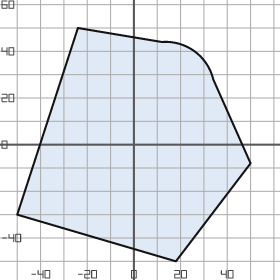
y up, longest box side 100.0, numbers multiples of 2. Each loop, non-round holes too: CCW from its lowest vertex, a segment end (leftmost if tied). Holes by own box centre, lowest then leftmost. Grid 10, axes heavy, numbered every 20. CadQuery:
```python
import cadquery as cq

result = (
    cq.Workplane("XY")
    .moveTo(18.0, -50.0)
    .lineTo(50.0, -8.0)
    .lineTo(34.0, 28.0)
    .threePointArc((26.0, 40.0), (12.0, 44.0))
    .lineTo(-24.0, 50.0)
    .lineTo(-50.0, -30.0)
    .close()
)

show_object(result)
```